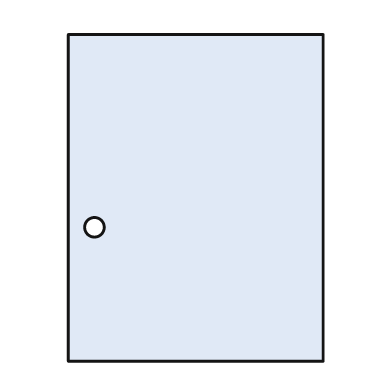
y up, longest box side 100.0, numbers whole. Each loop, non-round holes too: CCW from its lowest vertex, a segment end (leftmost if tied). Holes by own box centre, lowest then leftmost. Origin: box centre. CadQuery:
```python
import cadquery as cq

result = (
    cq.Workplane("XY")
    .moveTo(-39.0, -50.0)
    .lineTo(39.0, -50.0)
    .lineTo(39.0, 50.0)
    .lineTo(-39.0, 50.0)
    .close()
    .moveTo(-31.0, -9.0)
    .circle(3.0)
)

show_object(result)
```